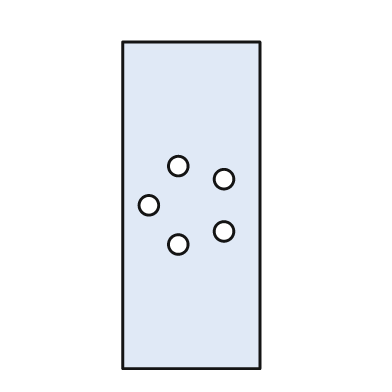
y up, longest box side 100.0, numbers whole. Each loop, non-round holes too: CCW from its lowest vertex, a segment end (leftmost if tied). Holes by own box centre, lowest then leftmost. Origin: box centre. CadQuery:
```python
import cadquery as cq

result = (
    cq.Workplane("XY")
    .moveTo(-21.0, -50.0)
    .lineTo(21.0, -50.0)
    .lineTo(21.0, 50.0)
    .lineTo(-21.0, 50.0)
    .close()
    .moveTo(-4.0, -12.0)
    .circle(3.0)
    .moveTo(10.0, -8.0)
    .circle(3.0)
    .moveTo(-13.0, 0.0)
    .circle(3.0)
    .moveTo(10.0, 8.0)
    .circle(3.0)
    .moveTo(-4.0, 12.0)
    .circle(3.0)
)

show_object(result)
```